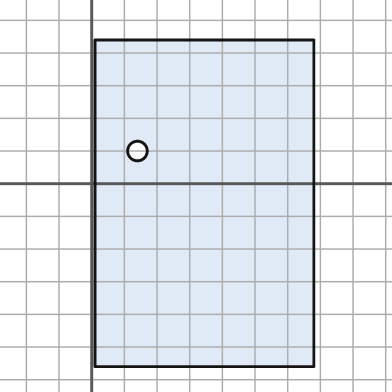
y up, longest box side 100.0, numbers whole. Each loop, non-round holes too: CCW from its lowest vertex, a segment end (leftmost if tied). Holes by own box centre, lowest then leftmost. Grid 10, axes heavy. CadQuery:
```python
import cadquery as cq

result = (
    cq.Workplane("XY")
    .moveTo(1.0, -56.0)
    .lineTo(68.0, -56.0)
    .lineTo(68.0, 44.0)
    .lineTo(1.0, 44.0)
    .close()
    .moveTo(14.0, 10.0)
    .circle(3.0)
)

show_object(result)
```